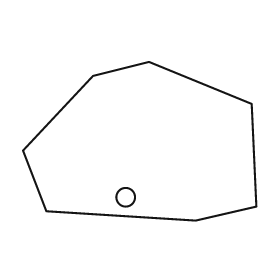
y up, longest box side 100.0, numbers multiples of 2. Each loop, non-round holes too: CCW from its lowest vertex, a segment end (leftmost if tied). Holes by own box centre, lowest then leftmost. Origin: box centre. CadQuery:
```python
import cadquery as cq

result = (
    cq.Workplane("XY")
    .moveTo(24.0, -34.0)
    .lineTo(50.0, -28.0)
    .lineTo(48.0, 16.0)
    .lineTo(4.0, 34.0)
    .lineTo(-20.0, 28.0)
    .lineTo(-50.0, -4.0)
    .lineTo(-40.0, -30.0)
    .close()
    .moveTo(-6.0, -24.0)
    .circle(4.0)
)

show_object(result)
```